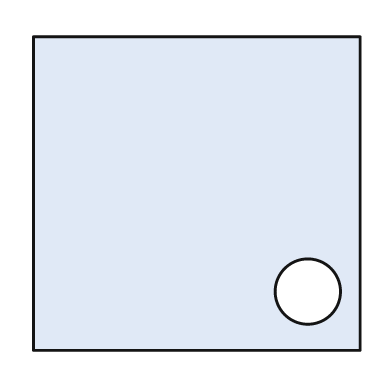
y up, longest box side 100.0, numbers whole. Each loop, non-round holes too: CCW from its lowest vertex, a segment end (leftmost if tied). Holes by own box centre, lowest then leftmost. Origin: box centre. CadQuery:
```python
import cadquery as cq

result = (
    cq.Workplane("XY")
    .moveTo(-50.0, -48.0)
    .lineTo(50.0, -48.0)
    .lineTo(50.0, 48.0)
    .lineTo(-50.0, 48.0)
    .close()
    .moveTo(34.0, -30.0)
    .circle(10.0)
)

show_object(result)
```